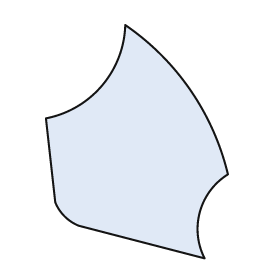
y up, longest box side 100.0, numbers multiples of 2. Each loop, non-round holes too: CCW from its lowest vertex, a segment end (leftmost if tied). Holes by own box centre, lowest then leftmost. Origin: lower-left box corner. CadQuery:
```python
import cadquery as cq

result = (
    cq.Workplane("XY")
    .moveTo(68.0, 0.0)
    .threePointArc((66.0, 20.0), (78.0, 36.0))
    .threePointArc((62.0, 72.0), (34.0, 100.0))
    .threePointArc((24.0, 74.0), (0.0, 60.0))
    .lineTo(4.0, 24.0)
    .threePointArc((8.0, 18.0), (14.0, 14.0))
    .close()
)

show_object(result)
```